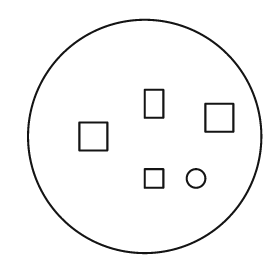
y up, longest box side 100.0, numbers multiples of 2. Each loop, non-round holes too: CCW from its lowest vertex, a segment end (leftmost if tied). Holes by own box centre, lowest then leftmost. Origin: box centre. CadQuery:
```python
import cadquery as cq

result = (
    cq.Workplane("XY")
    .moveTo(0.0, 0.0)
    .circle(50.0)
    .moveTo(0.0, -22.0)
    .lineTo(8.0, -22.0)
    .lineTo(8.0, -14.0)
    .lineTo(0.0, -14.0)
    .close()
    .moveTo(22.0, -18.0)
    .circle(4.0)
    .moveTo(-28.0, -6.0)
    .lineTo(-16.0, -6.0)
    .lineTo(-16.0, 6.0)
    .lineTo(-28.0, 6.0)
    .close()
    .moveTo(26.0, 2.0)
    .lineTo(38.0, 2.0)
    .lineTo(38.0, 14.0)
    .lineTo(26.0, 14.0)
    .close()
    .moveTo(0.0, 8.0)
    .lineTo(8.0, 8.0)
    .lineTo(8.0, 20.0)
    .lineTo(0.0, 20.0)
    .close()
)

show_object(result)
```